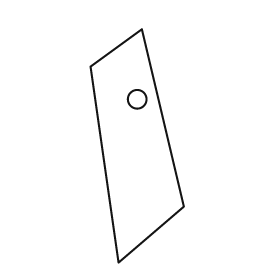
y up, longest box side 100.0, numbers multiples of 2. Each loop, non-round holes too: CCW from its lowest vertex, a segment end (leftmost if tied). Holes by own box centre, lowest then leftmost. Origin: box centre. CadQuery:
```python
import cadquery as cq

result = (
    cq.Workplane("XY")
    .moveTo(-8.0, -50.0)
    .lineTo(20.0, -26.0)
    .lineTo(2.0, 50.0)
    .lineTo(-20.0, 34.0)
    .close()
    .moveTo(0.0, 20.0)
    .circle(4.0)
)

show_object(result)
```